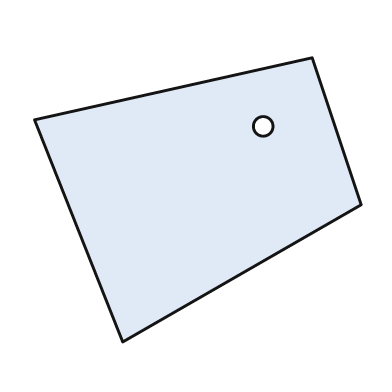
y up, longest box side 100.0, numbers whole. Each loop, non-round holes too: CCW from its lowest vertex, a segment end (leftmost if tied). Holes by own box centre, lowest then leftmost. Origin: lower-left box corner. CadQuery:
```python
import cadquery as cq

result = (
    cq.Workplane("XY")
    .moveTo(27.0, 0.0)
    .lineTo(100.0, 42.0)
    .lineTo(85.0, 87.0)
    .lineTo(0.0, 68.0)
    .close()
    .moveTo(70.0, 66.0)
    .circle(3.0)
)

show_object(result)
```